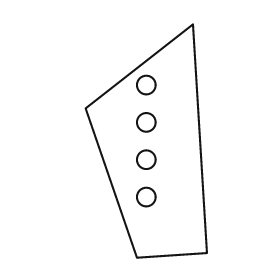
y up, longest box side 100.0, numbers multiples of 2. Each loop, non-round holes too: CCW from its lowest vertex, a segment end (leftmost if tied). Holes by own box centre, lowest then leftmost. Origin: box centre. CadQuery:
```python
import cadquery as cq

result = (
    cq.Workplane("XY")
    .moveTo(-4.0, -50.0)
    .lineTo(26.0, -48.0)
    .lineTo(20.0, 50.0)
    .lineTo(-26.0, 14.0)
    .close()
    .moveTo(0.0, -24.0)
    .circle(4.0)
    .moveTo(0.0, -8.0)
    .circle(4.0)
    .moveTo(0.0, 8.0)
    .circle(4.0)
    .moveTo(0.0, 24.0)
    .circle(4.0)
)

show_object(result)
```